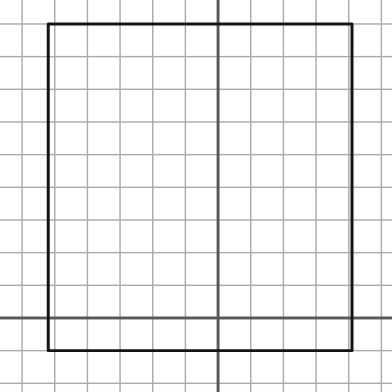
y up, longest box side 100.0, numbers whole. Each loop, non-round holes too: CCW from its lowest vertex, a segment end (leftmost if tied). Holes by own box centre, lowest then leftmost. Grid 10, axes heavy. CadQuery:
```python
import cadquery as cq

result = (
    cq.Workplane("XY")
    .moveTo(-52.0, -10.0)
    .lineTo(41.0, -10.0)
    .lineTo(41.0, 90.0)
    .lineTo(-52.0, 90.0)
    .close()
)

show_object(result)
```